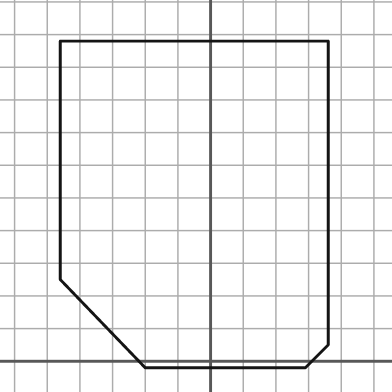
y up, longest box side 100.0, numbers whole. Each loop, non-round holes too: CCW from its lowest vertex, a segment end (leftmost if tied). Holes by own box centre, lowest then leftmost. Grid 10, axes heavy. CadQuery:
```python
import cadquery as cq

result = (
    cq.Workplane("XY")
    .moveTo(-20.0, -2.0)
    .lineTo(29.0, -2.0)
    .lineTo(36.0, 5.0)
    .lineTo(36.0, 98.0)
    .lineTo(-46.0, 98.0)
    .lineTo(-46.0, 25.0)
    .close()
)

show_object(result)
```